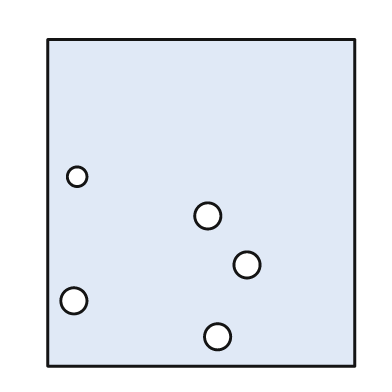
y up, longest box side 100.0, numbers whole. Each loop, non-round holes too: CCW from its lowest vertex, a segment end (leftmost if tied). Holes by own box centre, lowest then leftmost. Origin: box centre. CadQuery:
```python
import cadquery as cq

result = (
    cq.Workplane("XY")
    .moveTo(-47.0, -50.0)
    .lineTo(47.0, -50.0)
    .lineTo(47.0, 50.0)
    .lineTo(-47.0, 50.0)
    .close()
    .moveTo(5.0, -41.0)
    .circle(4.0)
    .moveTo(-39.0, -30.0)
    .circle(4.0)
    .moveTo(14.0, -19.0)
    .circle(4.0)
    .moveTo(2.0, -4.0)
    .circle(4.0)
    .moveTo(-38.0, 8.0)
    .circle(3.0)
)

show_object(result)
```